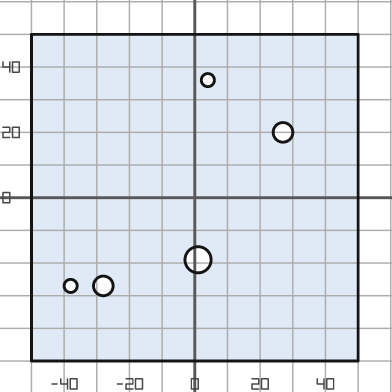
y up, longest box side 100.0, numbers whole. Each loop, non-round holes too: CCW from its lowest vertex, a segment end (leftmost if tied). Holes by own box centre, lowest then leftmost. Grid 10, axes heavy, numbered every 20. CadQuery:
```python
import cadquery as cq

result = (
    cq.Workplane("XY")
    .moveTo(-50.0, -50.0)
    .lineTo(50.0, -50.0)
    .lineTo(50.0, 50.0)
    .lineTo(-50.0, 50.0)
    .close()
    .moveTo(-38.0, -27.0)
    .circle(2.0)
    .moveTo(-28.0, -27.0)
    .circle(3.0)
    .moveTo(1.0, -19.0)
    .circle(4.0)
    .moveTo(27.0, 20.0)
    .circle(3.0)
    .moveTo(4.0, 36.0)
    .circle(2.0)
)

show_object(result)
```